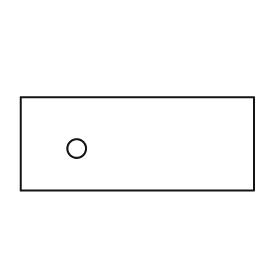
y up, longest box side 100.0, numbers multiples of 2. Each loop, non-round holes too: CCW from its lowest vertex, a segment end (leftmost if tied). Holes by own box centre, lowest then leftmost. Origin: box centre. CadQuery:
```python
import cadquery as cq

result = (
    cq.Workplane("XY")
    .moveTo(-50.0, -20.0)
    .lineTo(50.0, -20.0)
    .lineTo(50.0, 20.0)
    .lineTo(-50.0, 20.0)
    .close()
    .moveTo(-26.0, -2.0)
    .circle(4.0)
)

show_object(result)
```